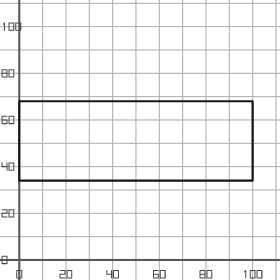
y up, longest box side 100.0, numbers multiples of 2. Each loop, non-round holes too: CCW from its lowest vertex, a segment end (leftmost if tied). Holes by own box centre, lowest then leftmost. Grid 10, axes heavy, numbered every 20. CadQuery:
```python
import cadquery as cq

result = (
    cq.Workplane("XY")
    .moveTo(0.0, 34.0)
    .lineTo(100.0, 34.0)
    .lineTo(100.0, 68.0)
    .lineTo(0.0, 68.0)
    .close()
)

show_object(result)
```